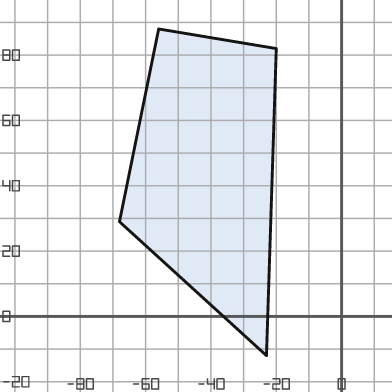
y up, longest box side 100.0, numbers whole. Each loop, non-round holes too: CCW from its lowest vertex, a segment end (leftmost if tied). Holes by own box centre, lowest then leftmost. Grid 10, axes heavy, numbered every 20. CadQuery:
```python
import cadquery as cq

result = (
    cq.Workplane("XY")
    .moveTo(-23.0, -12.0)
    .lineTo(-20.0, 82.0)
    .lineTo(-56.0, 88.0)
    .lineTo(-68.0, 29.0)
    .close()
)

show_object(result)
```